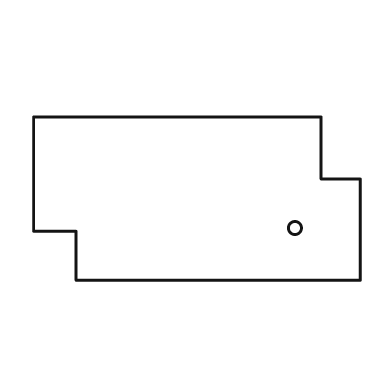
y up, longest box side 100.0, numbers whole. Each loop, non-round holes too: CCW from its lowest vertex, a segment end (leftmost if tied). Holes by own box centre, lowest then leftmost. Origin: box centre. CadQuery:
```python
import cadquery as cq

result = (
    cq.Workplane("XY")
    .moveTo(-37.0, -25.0)
    .lineTo(50.0, -25.0)
    .lineTo(50.0, 6.0)
    .lineTo(38.0, 6.0)
    .lineTo(38.0, 25.0)
    .lineTo(-50.0, 25.0)
    .lineTo(-50.0, -10.0)
    .lineTo(-37.0, -10.0)
    .close()
    .moveTo(30.0, -9.0)
    .circle(2.0)
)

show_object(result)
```